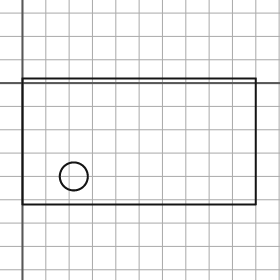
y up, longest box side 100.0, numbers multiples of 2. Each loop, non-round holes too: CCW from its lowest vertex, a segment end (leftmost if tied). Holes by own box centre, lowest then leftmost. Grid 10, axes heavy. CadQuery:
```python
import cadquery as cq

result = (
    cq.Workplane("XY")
    .moveTo(0.0, -52.0)
    .lineTo(100.0, -52.0)
    .lineTo(100.0, 2.0)
    .lineTo(0.0, 2.0)
    .close()
    .moveTo(22.0, -40.0)
    .circle(6.0)
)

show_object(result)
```